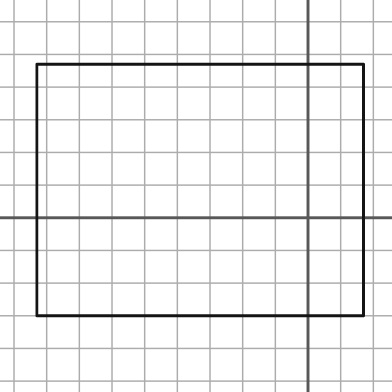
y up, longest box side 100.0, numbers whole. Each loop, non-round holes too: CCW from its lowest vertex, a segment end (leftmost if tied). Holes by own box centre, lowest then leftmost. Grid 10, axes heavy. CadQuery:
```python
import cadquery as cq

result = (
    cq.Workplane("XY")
    .moveTo(-83.0, -30.0)
    .lineTo(17.0, -30.0)
    .lineTo(17.0, 47.0)
    .lineTo(-83.0, 47.0)
    .close()
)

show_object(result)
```